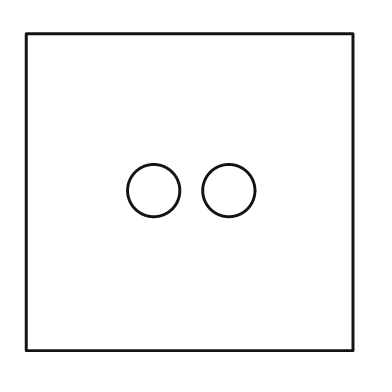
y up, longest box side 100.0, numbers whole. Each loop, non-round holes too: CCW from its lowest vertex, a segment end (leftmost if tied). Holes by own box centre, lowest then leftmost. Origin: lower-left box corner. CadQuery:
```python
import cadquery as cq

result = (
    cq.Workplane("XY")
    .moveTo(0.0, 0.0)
    .lineTo(100.0, 0.0)
    .lineTo(100.0, 97.0)
    .lineTo(0.0, 97.0)
    .close()
    .moveTo(39.0, 49.0)
    .circle(8.0)
    .moveTo(62.0, 49.0)
    .circle(8.0)
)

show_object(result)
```